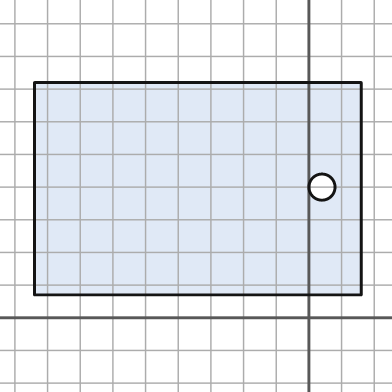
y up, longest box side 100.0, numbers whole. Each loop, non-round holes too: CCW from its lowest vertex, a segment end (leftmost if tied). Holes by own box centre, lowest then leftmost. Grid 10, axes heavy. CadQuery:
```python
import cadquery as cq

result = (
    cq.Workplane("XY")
    .moveTo(-84.0, 7.0)
    .lineTo(16.0, 7.0)
    .lineTo(16.0, 72.0)
    .lineTo(-84.0, 72.0)
    .close()
    .moveTo(4.0, 40.0)
    .circle(4.0)
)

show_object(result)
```